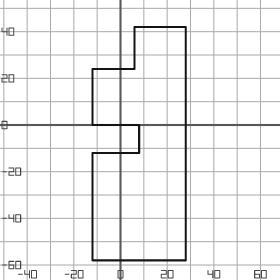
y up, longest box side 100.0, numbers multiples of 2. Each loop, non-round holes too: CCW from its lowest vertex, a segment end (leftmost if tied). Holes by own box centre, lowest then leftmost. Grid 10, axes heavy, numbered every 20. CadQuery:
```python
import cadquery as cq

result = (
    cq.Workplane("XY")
    .moveTo(-12.0, -58.0)
    .lineTo(28.0, -58.0)
    .lineTo(28.0, 42.0)
    .lineTo(6.0, 42.0)
    .lineTo(6.0, 24.0)
    .lineTo(-12.0, 24.0)
    .lineTo(-12.0, 0.0)
    .lineTo(8.0, 0.0)
    .lineTo(8.0, -12.0)
    .lineTo(-12.0, -12.0)
    .close()
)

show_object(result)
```